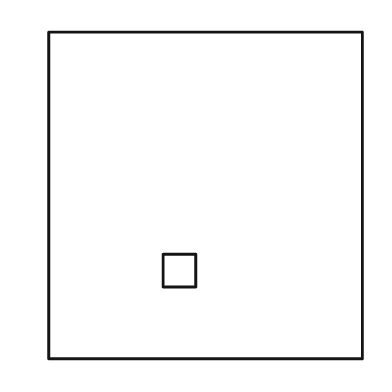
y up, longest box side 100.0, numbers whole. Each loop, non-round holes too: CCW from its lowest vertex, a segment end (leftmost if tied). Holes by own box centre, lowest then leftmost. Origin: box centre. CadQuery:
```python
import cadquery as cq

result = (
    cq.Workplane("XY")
    .moveTo(-48.0, -50.0)
    .lineTo(48.0, -50.0)
    .lineTo(48.0, 50.0)
    .lineTo(-48.0, 50.0)
    .close()
    .moveTo(-13.0, -28.0)
    .lineTo(-3.0, -28.0)
    .lineTo(-3.0, -18.0)
    .lineTo(-13.0, -18.0)
    .close()
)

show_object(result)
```